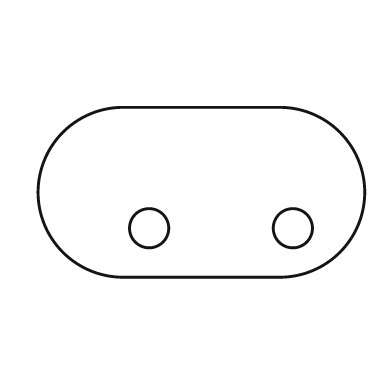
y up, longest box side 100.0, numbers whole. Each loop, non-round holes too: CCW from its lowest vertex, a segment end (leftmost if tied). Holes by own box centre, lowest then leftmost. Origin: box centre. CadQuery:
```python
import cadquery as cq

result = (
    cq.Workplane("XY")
    .moveTo(-24.0, -26.0)
    .lineTo(24.0, -26.0)
    .threePointArc((50.0, 0.0), (24.0, 26.0))
    .lineTo(-24.0, 26.0)
    .threePointArc((-50.0, 0.0), (-24.0, -26.0))
    .close()
    .moveTo(-16.0, -11.0)
    .circle(6.0)
    .moveTo(28.0, -11.0)
    .circle(6.0)
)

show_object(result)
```